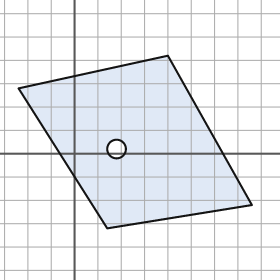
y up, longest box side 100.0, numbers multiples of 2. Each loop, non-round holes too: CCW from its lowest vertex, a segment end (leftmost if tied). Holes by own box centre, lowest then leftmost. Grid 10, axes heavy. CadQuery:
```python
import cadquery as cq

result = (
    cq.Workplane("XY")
    .moveTo(14.0, -32.0)
    .lineTo(76.0, -22.0)
    .lineTo(40.0, 42.0)
    .lineTo(-24.0, 28.0)
    .close()
    .moveTo(18.0, 2.0)
    .circle(4.0)
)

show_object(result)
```